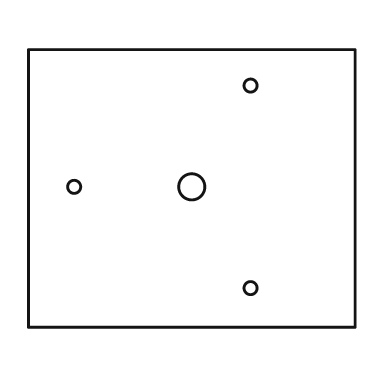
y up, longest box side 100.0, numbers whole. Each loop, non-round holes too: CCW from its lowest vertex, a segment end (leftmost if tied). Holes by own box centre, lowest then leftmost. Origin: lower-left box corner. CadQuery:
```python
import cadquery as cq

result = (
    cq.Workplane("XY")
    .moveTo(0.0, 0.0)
    .lineTo(100.0, 0.0)
    .lineTo(100.0, 85.0)
    .lineTo(0.0, 85.0)
    .close()
    .moveTo(68.0, 12.0)
    .circle(2.0)
    .moveTo(14.0, 43.0)
    .circle(2.0)
    .moveTo(50.0, 43.0)
    .circle(4.0)
    .moveTo(68.0, 74.0)
    .circle(2.0)
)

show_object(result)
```